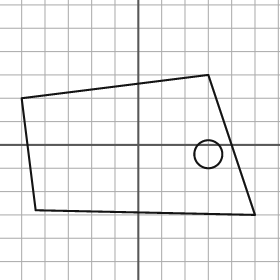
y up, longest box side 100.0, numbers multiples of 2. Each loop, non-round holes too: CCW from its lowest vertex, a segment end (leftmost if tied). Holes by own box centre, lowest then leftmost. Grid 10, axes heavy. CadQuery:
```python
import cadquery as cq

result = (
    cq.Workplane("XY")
    .moveTo(50.0, -30.0)
    .lineTo(30.0, 30.0)
    .lineTo(-50.0, 20.0)
    .lineTo(-44.0, -28.0)
    .close()
    .moveTo(30.0, -4.0)
    .circle(6.0)
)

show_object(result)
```